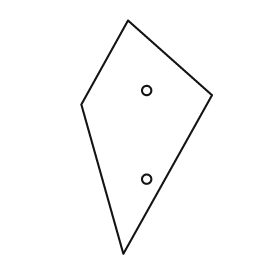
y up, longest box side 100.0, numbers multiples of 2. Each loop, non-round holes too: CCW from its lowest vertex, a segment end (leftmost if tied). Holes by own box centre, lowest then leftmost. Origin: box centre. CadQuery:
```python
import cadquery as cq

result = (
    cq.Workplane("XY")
    .moveTo(-10.0, -50.0)
    .lineTo(28.0, 18.0)
    .lineTo(-8.0, 50.0)
    .lineTo(-28.0, 14.0)
    .close()
    .moveTo(0.0, -18.0)
    .circle(2.0)
    .moveTo(0.0, 20.0)
    .circle(2.0)
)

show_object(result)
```